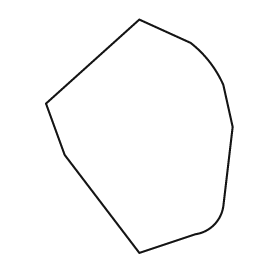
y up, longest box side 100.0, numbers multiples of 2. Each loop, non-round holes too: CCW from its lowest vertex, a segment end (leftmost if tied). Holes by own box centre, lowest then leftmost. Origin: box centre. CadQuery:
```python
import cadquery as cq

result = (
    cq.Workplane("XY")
    .moveTo(0.0, -50.0)
    .lineTo(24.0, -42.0)
    .threePointArc((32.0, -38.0), (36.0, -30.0))
    .lineTo(40.0, 4.0)
    .lineTo(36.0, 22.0)
    .threePointArc((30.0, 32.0), (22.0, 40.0))
    .lineTo(0.0, 50.0)
    .lineTo(-40.0, 14.0)
    .lineTo(-32.0, -8.0)
    .close()
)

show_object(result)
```